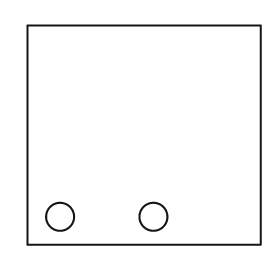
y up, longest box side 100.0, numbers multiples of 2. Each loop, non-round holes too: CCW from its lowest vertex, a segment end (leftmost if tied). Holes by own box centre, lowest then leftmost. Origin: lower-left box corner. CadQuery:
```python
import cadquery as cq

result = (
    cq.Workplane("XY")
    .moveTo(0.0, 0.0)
    .lineTo(100.0, 0.0)
    .lineTo(100.0, 94.0)
    .lineTo(0.0, 94.0)
    .close()
    .moveTo(14.0, 12.0)
    .circle(6.0)
    .moveTo(54.0, 12.0)
    .circle(6.0)
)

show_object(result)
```